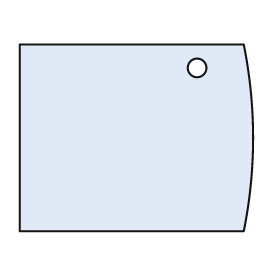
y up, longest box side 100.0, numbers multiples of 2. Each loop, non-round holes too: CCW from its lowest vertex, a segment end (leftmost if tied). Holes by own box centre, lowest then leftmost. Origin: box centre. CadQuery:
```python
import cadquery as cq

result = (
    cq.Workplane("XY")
    .moveTo(-50.0, -40.0)
    .lineTo(46.0, -40.0)
    .threePointArc((50.0, 0.0), (46.0, 40.0))
    .lineTo(-50.0, 40.0)
    .close()
    .moveTo(26.0, 30.0)
    .circle(4.0)
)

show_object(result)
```